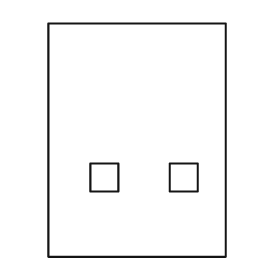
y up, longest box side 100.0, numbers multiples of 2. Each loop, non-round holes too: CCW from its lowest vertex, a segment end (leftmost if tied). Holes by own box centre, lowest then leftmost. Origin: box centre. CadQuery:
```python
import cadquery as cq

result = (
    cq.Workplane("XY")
    .moveTo(-38.0, -50.0)
    .lineTo(38.0, -50.0)
    .lineTo(38.0, 50.0)
    .lineTo(-38.0, 50.0)
    .close()
    .moveTo(-20.0, -22.0)
    .lineTo(-8.0, -22.0)
    .lineTo(-8.0, -10.0)
    .lineTo(-20.0, -10.0)
    .close()
    .moveTo(14.0, -22.0)
    .lineTo(26.0, -22.0)
    .lineTo(26.0, -10.0)
    .lineTo(14.0, -10.0)
    .close()
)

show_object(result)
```